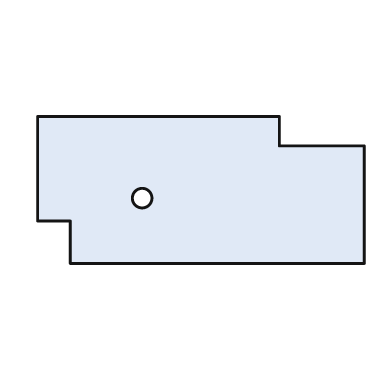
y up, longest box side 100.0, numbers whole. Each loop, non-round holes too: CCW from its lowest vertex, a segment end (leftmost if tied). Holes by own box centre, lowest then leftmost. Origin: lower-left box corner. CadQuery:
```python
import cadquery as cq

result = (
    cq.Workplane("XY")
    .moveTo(10.0, 0.0)
    .lineTo(100.0, 0.0)
    .lineTo(100.0, 36.0)
    .lineTo(74.0, 36.0)
    .lineTo(74.0, 45.0)
    .lineTo(0.0, 45.0)
    .lineTo(0.0, 13.0)
    .lineTo(10.0, 13.0)
    .close()
    .moveTo(32.0, 20.0)
    .circle(3.0)
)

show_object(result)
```